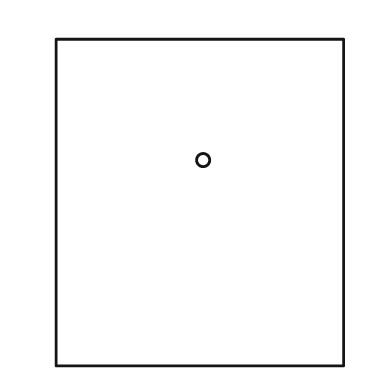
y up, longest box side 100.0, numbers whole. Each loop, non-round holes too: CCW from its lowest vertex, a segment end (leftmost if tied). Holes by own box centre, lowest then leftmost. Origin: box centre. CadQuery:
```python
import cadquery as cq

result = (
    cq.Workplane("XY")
    .moveTo(-44.0, -50.0)
    .lineTo(44.0, -50.0)
    .lineTo(44.0, 50.0)
    .lineTo(-44.0, 50.0)
    .close()
    .moveTo(1.0, 13.0)
    .circle(2.0)
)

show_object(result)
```